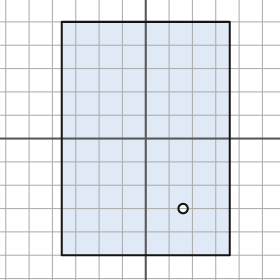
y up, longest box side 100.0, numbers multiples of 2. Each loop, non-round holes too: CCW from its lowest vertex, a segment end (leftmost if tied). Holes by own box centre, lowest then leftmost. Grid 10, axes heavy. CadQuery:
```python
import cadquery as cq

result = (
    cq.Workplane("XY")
    .moveTo(-36.0, -50.0)
    .lineTo(36.0, -50.0)
    .lineTo(36.0, 50.0)
    .lineTo(-36.0, 50.0)
    .close()
    .moveTo(16.0, -30.0)
    .circle(2.0)
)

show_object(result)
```